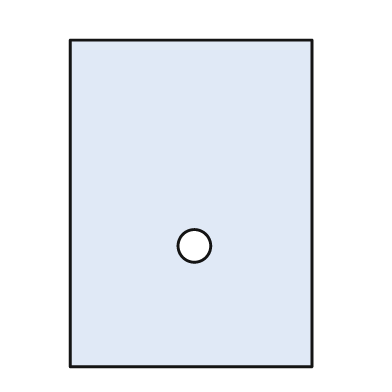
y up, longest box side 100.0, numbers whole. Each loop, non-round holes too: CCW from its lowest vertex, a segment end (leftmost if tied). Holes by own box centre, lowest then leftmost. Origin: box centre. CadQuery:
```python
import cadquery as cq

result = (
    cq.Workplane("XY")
    .moveTo(-37.0, -50.0)
    .lineTo(37.0, -50.0)
    .lineTo(37.0, 50.0)
    .lineTo(-37.0, 50.0)
    .close()
    .moveTo(1.0, -13.0)
    .circle(5.0)
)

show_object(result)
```